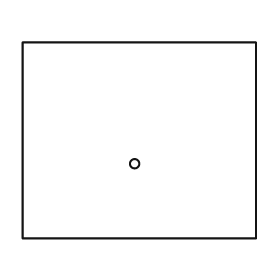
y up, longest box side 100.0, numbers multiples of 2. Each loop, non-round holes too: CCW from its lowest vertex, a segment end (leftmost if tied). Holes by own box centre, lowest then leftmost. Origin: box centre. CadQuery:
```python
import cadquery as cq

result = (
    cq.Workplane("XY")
    .moveTo(-50.0, -42.0)
    .lineTo(50.0, -42.0)
    .lineTo(50.0, 42.0)
    .lineTo(-50.0, 42.0)
    .close()
    .moveTo(-2.0, -10.0)
    .circle(2.0)
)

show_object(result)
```